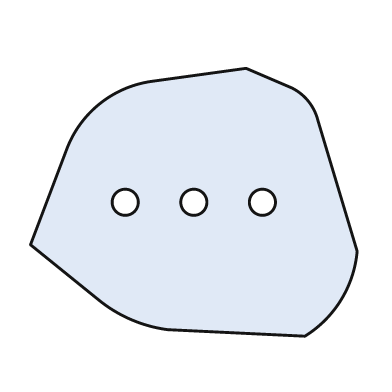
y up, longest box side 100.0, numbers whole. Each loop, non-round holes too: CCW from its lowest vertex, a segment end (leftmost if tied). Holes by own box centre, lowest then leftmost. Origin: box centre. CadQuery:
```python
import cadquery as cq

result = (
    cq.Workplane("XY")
    .moveTo(34.0, -41.0)
    .threePointArc((45.0, -30.0), (50.0, -15.0))
    .lineTo(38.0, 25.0)
    .threePointArc((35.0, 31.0), (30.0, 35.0))
    .lineTo(16.0, 41.0)
    .lineTo(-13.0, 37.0)
    .threePointArc((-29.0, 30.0), (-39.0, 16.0))
    .lineTo(-50.0, -13.0)
    .lineTo(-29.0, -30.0)
    .threePointArc((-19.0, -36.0), (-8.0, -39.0))
    .close()
    .moveTo(-21.0, 0.0)
    .circle(4.0)
    .moveTo(0.0, 0.0)
    .circle(4.0)
    .moveTo(21.0, 0.0)
    .circle(4.0)
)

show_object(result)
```